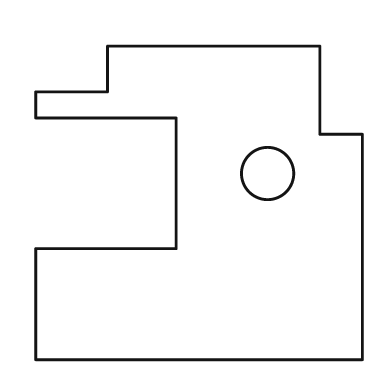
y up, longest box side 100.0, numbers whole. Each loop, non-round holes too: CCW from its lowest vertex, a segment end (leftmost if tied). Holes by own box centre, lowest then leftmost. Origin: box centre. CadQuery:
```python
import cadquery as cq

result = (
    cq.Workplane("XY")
    .moveTo(-50.0, -48.0)
    .lineTo(50.0, -48.0)
    .lineTo(50.0, 21.0)
    .lineTo(37.0, 21.0)
    .lineTo(37.0, 48.0)
    .lineTo(-28.0, 48.0)
    .lineTo(-28.0, 34.0)
    .lineTo(-50.0, 34.0)
    .lineTo(-50.0, 26.0)
    .lineTo(-7.0, 26.0)
    .lineTo(-7.0, -14.0)
    .lineTo(-50.0, -14.0)
    .close()
    .moveTo(21.0, 9.0)
    .circle(8.0)
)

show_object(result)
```